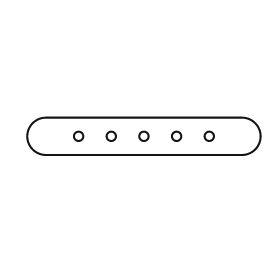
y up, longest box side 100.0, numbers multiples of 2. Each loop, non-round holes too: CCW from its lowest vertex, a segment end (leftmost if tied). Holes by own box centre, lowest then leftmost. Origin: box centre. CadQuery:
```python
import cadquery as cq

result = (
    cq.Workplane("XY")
    .moveTo(-42.0, -8.0)
    .lineTo(42.0, -8.0)
    .threePointArc((50.0, 0.0), (42.0, 8.0))
    .lineTo(-42.0, 8.0)
    .threePointArc((-50.0, 0.0), (-42.0, -8.0))
    .close()
    .moveTo(-28.0, 0.0)
    .circle(2.0)
    .moveTo(-14.0, 0.0)
    .circle(2.0)
    .moveTo(0.0, 0.0)
    .circle(2.0)
    .moveTo(14.0, 0.0)
    .circle(2.0)
    .moveTo(28.0, 0.0)
    .circle(2.0)
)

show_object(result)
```